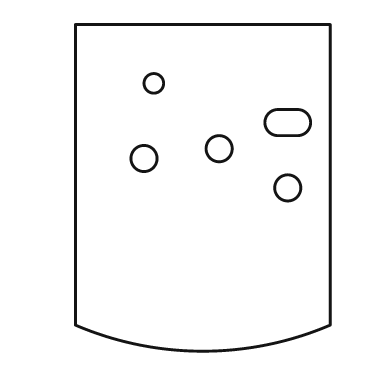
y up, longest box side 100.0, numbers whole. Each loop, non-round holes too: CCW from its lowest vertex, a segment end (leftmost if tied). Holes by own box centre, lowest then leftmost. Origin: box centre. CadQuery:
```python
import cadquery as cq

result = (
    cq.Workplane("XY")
    .moveTo(-39.0, -42.0)
    .threePointArc((0.0, -50.0), (39.0, -42.0))
    .lineTo(39.0, 50.0)
    .lineTo(-39.0, 50.0)
    .close()
    .moveTo(26.0, 0.0)
    .circle(4.0)
    .moveTo(-18.0, 9.0)
    .circle(4.0)
    .moveTo(5.0, 12.0)
    .circle(4.0)
    .moveTo(23.0, 16.0)
    .lineTo(29.0, 16.0)
    .threePointArc((33.0, 20.0), (29.0, 24.0))
    .lineTo(23.0, 24.0)
    .threePointArc((19.0, 20.0), (23.0, 16.0))
    .close()
    .moveTo(-15.0, 32.0)
    .circle(3.0)
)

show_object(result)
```